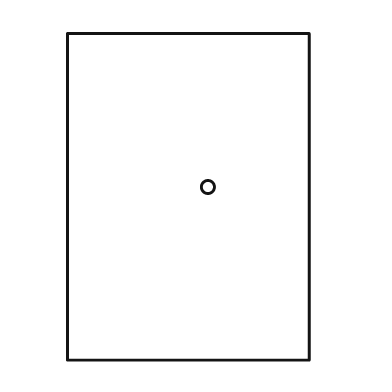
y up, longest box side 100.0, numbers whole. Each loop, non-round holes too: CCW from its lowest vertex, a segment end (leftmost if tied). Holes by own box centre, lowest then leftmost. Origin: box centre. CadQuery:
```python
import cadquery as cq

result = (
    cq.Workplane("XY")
    .moveTo(-37.0, -50.0)
    .lineTo(37.0, -50.0)
    .lineTo(37.0, 50.0)
    .lineTo(-37.0, 50.0)
    .close()
    .moveTo(6.0, 3.0)
    .circle(2.0)
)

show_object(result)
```